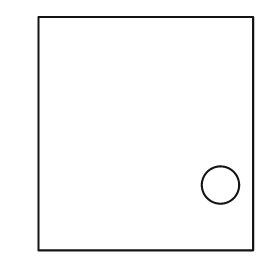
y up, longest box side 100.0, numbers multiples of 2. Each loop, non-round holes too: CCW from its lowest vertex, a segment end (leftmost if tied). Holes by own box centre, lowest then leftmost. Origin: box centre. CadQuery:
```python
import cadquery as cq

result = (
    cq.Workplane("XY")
    .moveTo(-46.0, -50.0)
    .lineTo(46.0, -50.0)
    .lineTo(46.0, 50.0)
    .lineTo(-46.0, 50.0)
    .close()
    .moveTo(32.0, -22.0)
    .circle(8.0)
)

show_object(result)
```